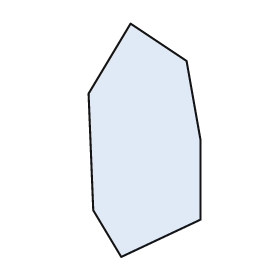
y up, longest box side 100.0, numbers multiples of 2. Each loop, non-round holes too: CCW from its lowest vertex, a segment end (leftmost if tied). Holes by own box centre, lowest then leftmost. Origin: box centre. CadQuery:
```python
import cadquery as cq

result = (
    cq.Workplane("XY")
    .moveTo(-10.0, -50.0)
    .lineTo(24.0, -34.0)
    .lineTo(24.0, 0.0)
    .lineTo(18.0, 34.0)
    .lineTo(-6.0, 50.0)
    .lineTo(-24.0, 20.0)
    .lineTo(-22.0, -30.0)
    .close()
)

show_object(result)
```